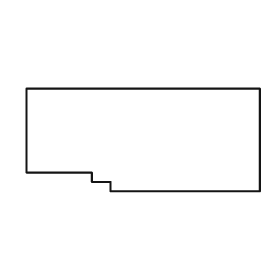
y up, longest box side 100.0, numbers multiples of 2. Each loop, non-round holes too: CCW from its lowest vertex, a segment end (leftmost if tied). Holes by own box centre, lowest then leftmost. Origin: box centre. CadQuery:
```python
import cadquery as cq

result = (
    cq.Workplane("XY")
    .moveTo(-14.0, -22.0)
    .lineTo(50.0, -22.0)
    .lineTo(50.0, 22.0)
    .lineTo(-50.0, 22.0)
    .lineTo(-50.0, -14.0)
    .lineTo(-22.0, -14.0)
    .lineTo(-22.0, -18.0)
    .lineTo(-14.0, -18.0)
    .close()
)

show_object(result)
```